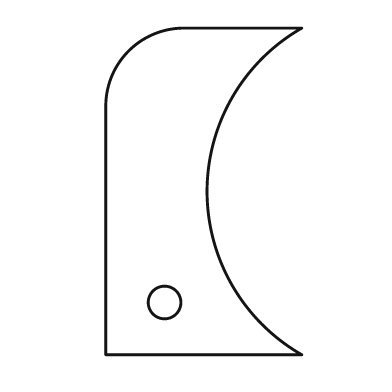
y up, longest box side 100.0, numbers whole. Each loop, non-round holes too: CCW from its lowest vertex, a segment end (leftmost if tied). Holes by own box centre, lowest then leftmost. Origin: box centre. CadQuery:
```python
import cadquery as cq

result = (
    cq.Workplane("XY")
    .moveTo(-30.0, -50.0)
    .lineTo(30.0, -50.0)
    .threePointArc((1.0, 0.0), (30.0, 50.0))
    .lineTo(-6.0, 50.0)
    .threePointArc((-23.0, 43.0), (-30.0, 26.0))
    .close()
    .moveTo(-12.0, -34.0)
    .circle(5.0)
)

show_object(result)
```